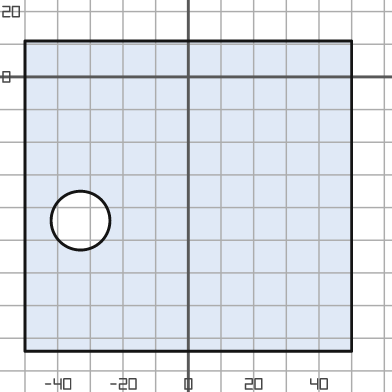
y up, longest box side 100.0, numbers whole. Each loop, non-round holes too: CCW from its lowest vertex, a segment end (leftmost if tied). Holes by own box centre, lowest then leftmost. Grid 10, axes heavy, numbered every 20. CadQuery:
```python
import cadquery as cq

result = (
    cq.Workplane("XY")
    .moveTo(-50.0, -84.0)
    .lineTo(50.0, -84.0)
    .lineTo(50.0, 11.0)
    .lineTo(-50.0, 11.0)
    .close()
    .moveTo(-33.0, -44.0)
    .circle(9.0)
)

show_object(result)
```